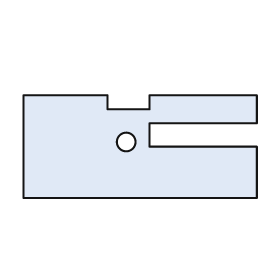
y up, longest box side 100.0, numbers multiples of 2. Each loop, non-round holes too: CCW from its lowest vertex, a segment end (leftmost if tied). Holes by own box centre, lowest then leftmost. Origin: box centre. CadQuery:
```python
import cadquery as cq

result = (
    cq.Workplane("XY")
    .moveTo(-50.0, -22.0)
    .lineTo(50.0, -22.0)
    .lineTo(50.0, 0.0)
    .lineTo(4.0, 0.0)
    .lineTo(4.0, 10.0)
    .lineTo(50.0, 10.0)
    .lineTo(50.0, 22.0)
    .lineTo(4.0, 22.0)
    .lineTo(4.0, 16.0)
    .lineTo(-14.0, 16.0)
    .lineTo(-14.0, 22.0)
    .lineTo(-50.0, 22.0)
    .close()
    .moveTo(-6.0, 2.0)
    .circle(4.0)
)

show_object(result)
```